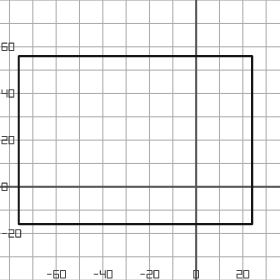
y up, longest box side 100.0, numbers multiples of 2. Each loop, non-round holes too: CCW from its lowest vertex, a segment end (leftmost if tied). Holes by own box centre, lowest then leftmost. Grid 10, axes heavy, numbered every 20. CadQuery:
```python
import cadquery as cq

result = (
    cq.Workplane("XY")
    .moveTo(-76.0, -16.0)
    .lineTo(24.0, -16.0)
    .lineTo(24.0, 56.0)
    .lineTo(-76.0, 56.0)
    .close()
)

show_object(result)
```